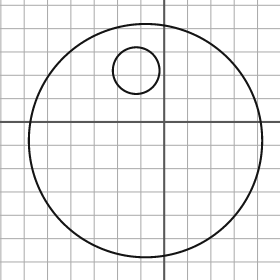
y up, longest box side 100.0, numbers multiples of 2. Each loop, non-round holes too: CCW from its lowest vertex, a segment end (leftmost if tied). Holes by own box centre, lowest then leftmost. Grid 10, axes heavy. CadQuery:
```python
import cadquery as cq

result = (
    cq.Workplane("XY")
    .moveTo(-8.0, -8.0)
    .circle(50.0)
    .moveTo(-12.0, 22.0)
    .circle(10.0)
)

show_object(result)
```